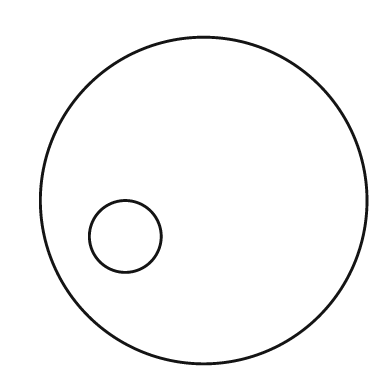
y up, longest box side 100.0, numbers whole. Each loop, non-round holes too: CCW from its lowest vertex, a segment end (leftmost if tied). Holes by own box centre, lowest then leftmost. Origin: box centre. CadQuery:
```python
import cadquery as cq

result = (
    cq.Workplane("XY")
    .moveTo(0.0, 0.0)
    .circle(50.0)
    .moveTo(-24.0, -11.0)
    .circle(11.0)
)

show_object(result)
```